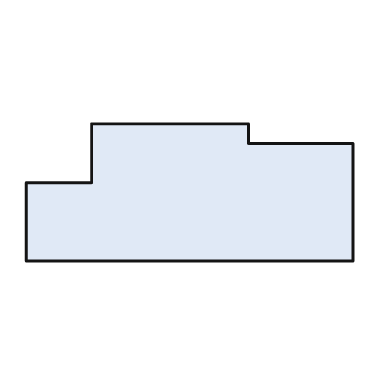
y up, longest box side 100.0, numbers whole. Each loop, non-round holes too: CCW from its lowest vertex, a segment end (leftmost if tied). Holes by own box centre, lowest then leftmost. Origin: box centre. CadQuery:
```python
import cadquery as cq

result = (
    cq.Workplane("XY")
    .moveTo(-50.0, -21.0)
    .lineTo(50.0, -21.0)
    .lineTo(50.0, 15.0)
    .lineTo(18.0, 15.0)
    .lineTo(18.0, 21.0)
    .lineTo(-30.0, 21.0)
    .lineTo(-30.0, 3.0)
    .lineTo(-50.0, 3.0)
    .close()
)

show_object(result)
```